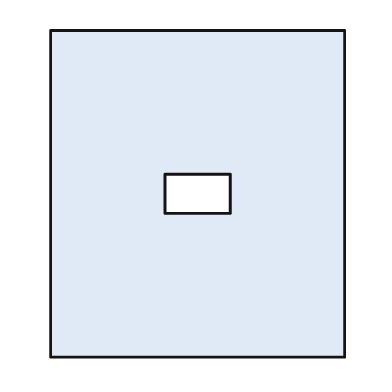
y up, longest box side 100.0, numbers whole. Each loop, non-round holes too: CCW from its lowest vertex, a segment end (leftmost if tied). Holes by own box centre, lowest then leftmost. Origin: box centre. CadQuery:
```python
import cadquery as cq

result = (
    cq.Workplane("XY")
    .moveTo(-45.0, -50.0)
    .lineTo(45.0, -50.0)
    .lineTo(45.0, 50.0)
    .lineTo(-45.0, 50.0)
    .close()
    .moveTo(-10.0, -6.0)
    .lineTo(10.0, -6.0)
    .lineTo(10.0, 6.0)
    .lineTo(-10.0, 6.0)
    .close()
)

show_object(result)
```